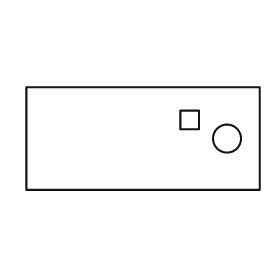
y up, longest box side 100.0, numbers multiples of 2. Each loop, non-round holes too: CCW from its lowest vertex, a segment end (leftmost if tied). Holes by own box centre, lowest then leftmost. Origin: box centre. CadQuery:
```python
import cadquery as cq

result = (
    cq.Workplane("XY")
    .moveTo(-50.0, -22.0)
    .lineTo(50.0, -22.0)
    .lineTo(50.0, 22.0)
    .lineTo(-50.0, 22.0)
    .close()
    .moveTo(36.0, 0.0)
    .circle(6.0)
    .moveTo(16.0, 4.0)
    .lineTo(24.0, 4.0)
    .lineTo(24.0, 12.0)
    .lineTo(16.0, 12.0)
    .close()
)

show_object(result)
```